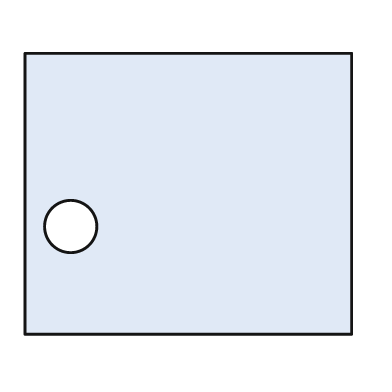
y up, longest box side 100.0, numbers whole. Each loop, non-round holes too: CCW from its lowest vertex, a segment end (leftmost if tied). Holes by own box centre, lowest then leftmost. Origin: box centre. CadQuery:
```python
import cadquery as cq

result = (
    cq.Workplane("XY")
    .moveTo(-50.0, -43.0)
    .lineTo(50.0, -43.0)
    .lineTo(50.0, 43.0)
    .lineTo(-50.0, 43.0)
    .close()
    .moveTo(-36.0, -10.0)
    .circle(8.0)
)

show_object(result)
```